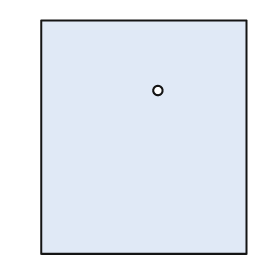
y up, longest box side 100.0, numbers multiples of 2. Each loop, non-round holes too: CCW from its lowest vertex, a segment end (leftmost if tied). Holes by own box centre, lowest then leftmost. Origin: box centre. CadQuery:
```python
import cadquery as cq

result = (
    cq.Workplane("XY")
    .moveTo(-44.0, -50.0)
    .lineTo(44.0, -50.0)
    .lineTo(44.0, 50.0)
    .lineTo(-44.0, 50.0)
    .close()
    .moveTo(6.0, 20.0)
    .circle(2.0)
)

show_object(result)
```